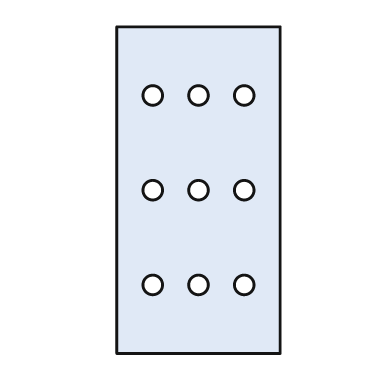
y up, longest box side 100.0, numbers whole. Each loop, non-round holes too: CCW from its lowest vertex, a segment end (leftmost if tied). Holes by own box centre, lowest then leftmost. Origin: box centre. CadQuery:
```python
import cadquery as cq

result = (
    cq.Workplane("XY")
    .moveTo(-25.0, -50.0)
    .lineTo(25.0, -50.0)
    .lineTo(25.0, 50.0)
    .lineTo(-25.0, 50.0)
    .close()
    .moveTo(-14.0, -29.0)
    .circle(3.0)
    .moveTo(0.0, -29.0)
    .circle(3.0)
    .moveTo(14.0, -29.0)
    .circle(3.0)
    .moveTo(-14.0, 0.0)
    .circle(3.0)
    .moveTo(0.0, 0.0)
    .circle(3.0)
    .moveTo(14.0, 0.0)
    .circle(3.0)
    .moveTo(-14.0, 29.0)
    .circle(3.0)
    .moveTo(0.0, 29.0)
    .circle(3.0)
    .moveTo(14.0, 29.0)
    .circle(3.0)
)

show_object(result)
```